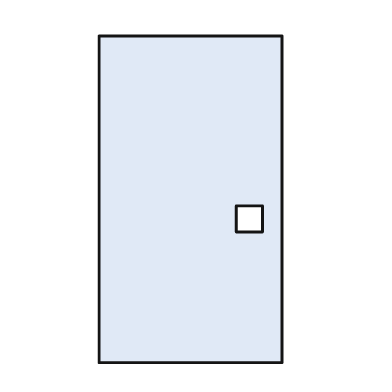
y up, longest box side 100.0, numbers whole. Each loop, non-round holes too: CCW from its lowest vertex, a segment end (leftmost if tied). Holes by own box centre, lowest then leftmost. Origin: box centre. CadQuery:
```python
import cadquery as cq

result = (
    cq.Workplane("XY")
    .moveTo(-28.0, -50.0)
    .lineTo(28.0, -50.0)
    .lineTo(28.0, 50.0)
    .lineTo(-28.0, 50.0)
    .close()
    .moveTo(14.0, -10.0)
    .lineTo(22.0, -10.0)
    .lineTo(22.0, -2.0)
    .lineTo(14.0, -2.0)
    .close()
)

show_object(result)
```